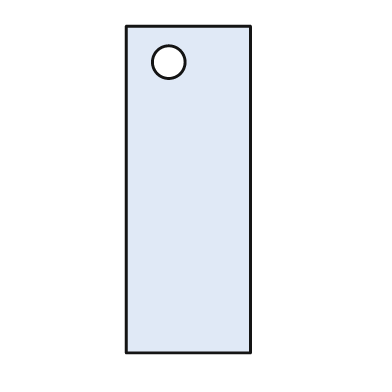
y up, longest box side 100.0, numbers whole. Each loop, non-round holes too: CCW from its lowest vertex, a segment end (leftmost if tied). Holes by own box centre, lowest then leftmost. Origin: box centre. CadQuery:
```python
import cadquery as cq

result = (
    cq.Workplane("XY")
    .moveTo(-19.0, -50.0)
    .lineTo(19.0, -50.0)
    .lineTo(19.0, 50.0)
    .lineTo(-19.0, 50.0)
    .close()
    .moveTo(-6.0, 39.0)
    .circle(5.0)
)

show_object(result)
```